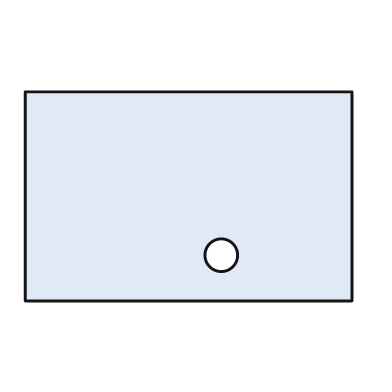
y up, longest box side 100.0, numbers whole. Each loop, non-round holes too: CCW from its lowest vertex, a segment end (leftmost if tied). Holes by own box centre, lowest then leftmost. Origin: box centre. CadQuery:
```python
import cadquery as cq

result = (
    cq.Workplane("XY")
    .moveTo(-50.0, -32.0)
    .lineTo(50.0, -32.0)
    .lineTo(50.0, 32.0)
    .lineTo(-50.0, 32.0)
    .close()
    .moveTo(10.0, -18.0)
    .circle(5.0)
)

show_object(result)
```